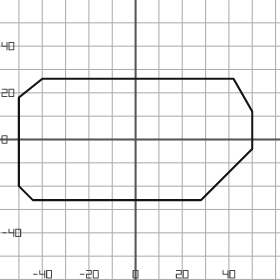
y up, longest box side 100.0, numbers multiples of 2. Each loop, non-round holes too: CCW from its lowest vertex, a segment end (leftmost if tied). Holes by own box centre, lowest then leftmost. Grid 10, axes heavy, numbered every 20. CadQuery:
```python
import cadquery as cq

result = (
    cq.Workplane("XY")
    .moveTo(-44.0, -26.0)
    .lineTo(28.0, -26.0)
    .lineTo(50.0, -4.0)
    .lineTo(50.0, 12.0)
    .lineTo(42.0, 26.0)
    .lineTo(-40.0, 26.0)
    .lineTo(-50.0, 18.0)
    .lineTo(-50.0, -20.0)
    .close()
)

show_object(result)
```